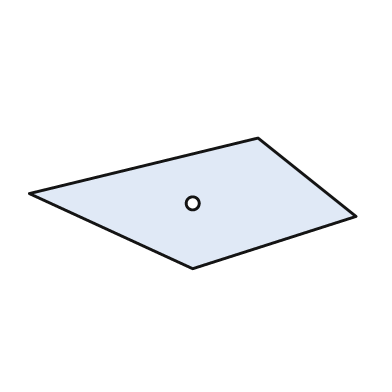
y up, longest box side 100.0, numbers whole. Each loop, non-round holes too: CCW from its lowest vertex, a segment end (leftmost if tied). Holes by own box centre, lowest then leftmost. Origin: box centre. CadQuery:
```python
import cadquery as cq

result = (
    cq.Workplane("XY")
    .moveTo(0.0, -20.0)
    .lineTo(50.0, -4.0)
    .lineTo(20.0, 20.0)
    .lineTo(-50.0, 3.0)
    .close()
    .moveTo(0.0, 0.0)
    .circle(2.0)
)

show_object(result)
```